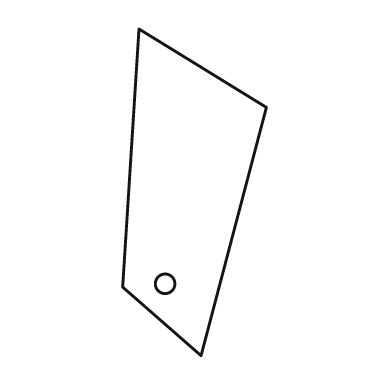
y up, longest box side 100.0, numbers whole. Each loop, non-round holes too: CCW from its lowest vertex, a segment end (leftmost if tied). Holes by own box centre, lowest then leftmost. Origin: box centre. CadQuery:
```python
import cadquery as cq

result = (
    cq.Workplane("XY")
    .moveTo(2.0, -50.0)
    .lineTo(22.0, 26.0)
    .lineTo(-17.0, 50.0)
    .lineTo(-22.0, -29.0)
    .close()
    .moveTo(-9.0, -28.0)
    .circle(3.0)
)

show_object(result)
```